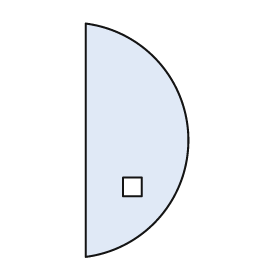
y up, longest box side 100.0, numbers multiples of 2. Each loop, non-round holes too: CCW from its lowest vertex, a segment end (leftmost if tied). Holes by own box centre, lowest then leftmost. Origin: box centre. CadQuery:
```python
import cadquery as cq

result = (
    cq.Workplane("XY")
    .moveTo(-22.0, -50.0)
    .threePointArc((22.0, 0.0), (-22.0, 50.0))
    .close()
    .moveTo(-6.0, -24.0)
    .lineTo(2.0, -24.0)
    .lineTo(2.0, -16.0)
    .lineTo(-6.0, -16.0)
    .close()
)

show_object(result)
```